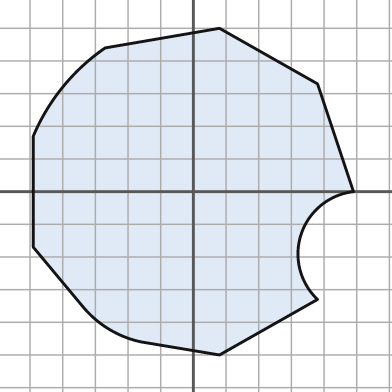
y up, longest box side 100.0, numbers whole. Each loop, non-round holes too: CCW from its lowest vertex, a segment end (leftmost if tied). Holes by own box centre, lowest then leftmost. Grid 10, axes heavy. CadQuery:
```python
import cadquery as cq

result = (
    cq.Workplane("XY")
    .moveTo(8.0, -50.0)
    .lineTo(38.0, -33.0)
    .threePointArc((33.0, -13.0), (49.0, 0.0))
    .lineTo(38.0, 33.0)
    .lineTo(8.0, 50.0)
    .lineTo(-27.0, 44.0)
    .threePointArc((-40.0, 32.0), (-49.0, 17.0))
    .lineTo(-49.0, -17.0)
    .lineTo(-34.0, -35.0)
    .threePointArc((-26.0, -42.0), (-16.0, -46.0))
    .close()
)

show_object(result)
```